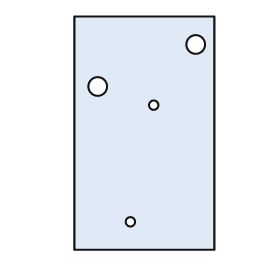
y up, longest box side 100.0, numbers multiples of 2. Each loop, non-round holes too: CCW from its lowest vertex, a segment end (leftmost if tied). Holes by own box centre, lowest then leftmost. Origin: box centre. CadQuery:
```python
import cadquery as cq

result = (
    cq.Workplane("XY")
    .moveTo(-30.0, -50.0)
    .lineTo(30.0, -50.0)
    .lineTo(30.0, 50.0)
    .lineTo(-30.0, 50.0)
    .close()
    .moveTo(-6.0, -38.0)
    .circle(2.0)
    .moveTo(4.0, 12.0)
    .circle(2.0)
    .moveTo(-20.0, 20.0)
    .circle(4.0)
    .moveTo(22.0, 38.0)
    .circle(4.0)
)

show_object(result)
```